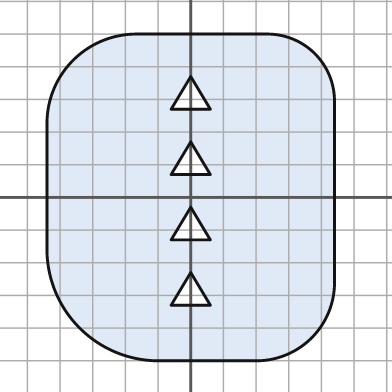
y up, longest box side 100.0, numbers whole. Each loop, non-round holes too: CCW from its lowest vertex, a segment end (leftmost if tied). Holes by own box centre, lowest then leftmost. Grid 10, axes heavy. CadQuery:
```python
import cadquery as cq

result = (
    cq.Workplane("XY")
    .moveTo(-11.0, -50.0)
    .lineTo(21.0, -50.0)
    .threePointArc((37.0, -43.0), (44.0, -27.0))
    .lineTo(44.0, 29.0)
    .threePointArc((38.0, 44.0), (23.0, 50.0))
    .lineTo(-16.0, 50.0)
    .threePointArc((-36.0, 42.0), (-44.0, 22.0))
    .lineTo(-44.0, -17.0)
    .threePointArc((-34.0, -40.0), (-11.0, -50.0))
    .close()
    .moveTo(-6.0, -33.0)
    .lineTo(6.0, -33.0)
    .lineTo(0.0, -23.0)
    .close()
    .moveTo(-6.0, -13.0)
    .lineTo(6.0, -13.0)
    .lineTo(0.0, -3.0)
    .close()
    .moveTo(-6.0, 7.0)
    .lineTo(6.0, 7.0)
    .lineTo(0.0, 17.0)
    .close()
    .moveTo(-6.0, 27.0)
    .lineTo(6.0, 27.0)
    .lineTo(0.0, 37.0)
    .close()
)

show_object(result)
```